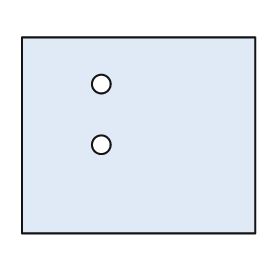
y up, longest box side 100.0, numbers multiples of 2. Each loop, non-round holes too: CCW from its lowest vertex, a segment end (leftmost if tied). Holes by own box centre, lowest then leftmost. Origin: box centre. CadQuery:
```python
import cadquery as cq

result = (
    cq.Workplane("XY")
    .moveTo(-50.0, -42.0)
    .lineTo(50.0, -42.0)
    .lineTo(50.0, 42.0)
    .lineTo(-50.0, 42.0)
    .close()
    .moveTo(-16.0, -4.0)
    .circle(4.0)
    .moveTo(-16.0, 22.0)
    .circle(4.0)
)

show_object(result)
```